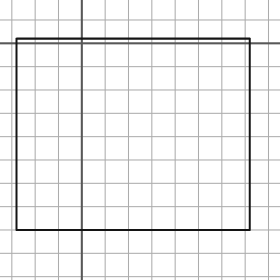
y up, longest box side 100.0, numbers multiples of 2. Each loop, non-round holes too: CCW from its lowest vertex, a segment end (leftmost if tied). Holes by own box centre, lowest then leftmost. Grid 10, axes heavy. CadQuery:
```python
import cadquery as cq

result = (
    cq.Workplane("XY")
    .moveTo(-28.0, -80.0)
    .lineTo(72.0, -80.0)
    .lineTo(72.0, 2.0)
    .lineTo(-28.0, 2.0)
    .close()
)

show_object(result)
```